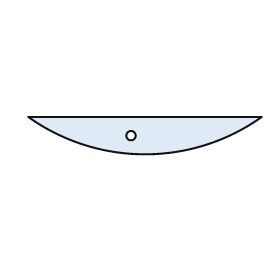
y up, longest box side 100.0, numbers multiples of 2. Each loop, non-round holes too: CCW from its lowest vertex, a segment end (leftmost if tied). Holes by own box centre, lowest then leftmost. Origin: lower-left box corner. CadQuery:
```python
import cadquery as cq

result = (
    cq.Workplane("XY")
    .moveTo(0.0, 16.0)
    .threePointArc((50.0, 0.0), (100.0, 16.0))
    .close()
    .moveTo(44.0, 8.0)
    .circle(2.0)
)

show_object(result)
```